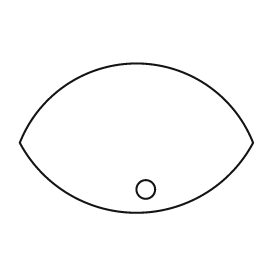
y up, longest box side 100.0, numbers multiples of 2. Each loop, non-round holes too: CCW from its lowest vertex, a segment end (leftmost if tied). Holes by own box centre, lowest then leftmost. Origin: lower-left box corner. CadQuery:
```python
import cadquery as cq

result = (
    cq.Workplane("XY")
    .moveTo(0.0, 30.0)
    .threePointArc((50.0, 0.0), (100.0, 30.0))
    .threePointArc((50.0, 64.0), (0.0, 30.0))
    .close()
    .moveTo(54.0, 10.0)
    .circle(4.0)
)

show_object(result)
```